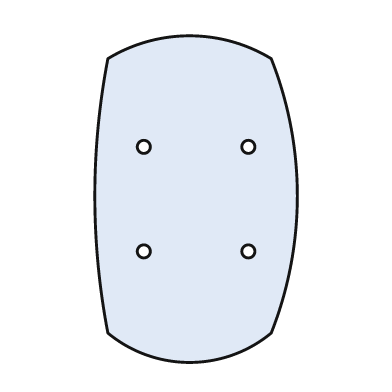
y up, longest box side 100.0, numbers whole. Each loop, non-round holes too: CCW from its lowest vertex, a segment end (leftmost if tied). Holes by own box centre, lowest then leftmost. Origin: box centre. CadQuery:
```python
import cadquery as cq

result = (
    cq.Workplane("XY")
    .moveTo(-27.0, -41.0)
    .threePointArc((-2.0, -50.0), (23.0, -41.0))
    .threePointArc((31.0, 1.0), (23.0, 43.0))
    .threePointArc((-2.0, 50.0), (-27.0, 43.0))
    .threePointArc((-31.0, 1.0), (-27.0, -41.0))
    .close()
    .moveTo(-16.0, -16.0)
    .circle(2.0)
    .moveTo(16.0, -16.0)
    .circle(2.0)
    .moveTo(-16.0, 16.0)
    .circle(2.0)
    .moveTo(16.0, 16.0)
    .circle(2.0)
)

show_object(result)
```